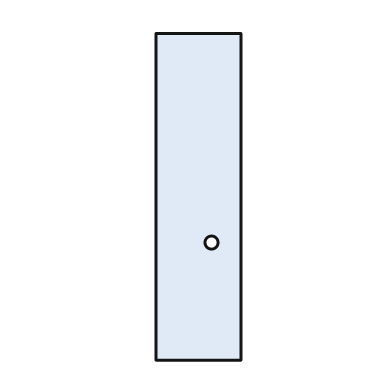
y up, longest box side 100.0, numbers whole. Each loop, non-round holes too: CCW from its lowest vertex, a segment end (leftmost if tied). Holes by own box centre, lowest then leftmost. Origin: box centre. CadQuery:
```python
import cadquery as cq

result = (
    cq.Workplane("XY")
    .moveTo(-13.0, -50.0)
    .lineTo(13.0, -50.0)
    .lineTo(13.0, 50.0)
    .lineTo(-13.0, 50.0)
    .close()
    .moveTo(4.0, -14.0)
    .circle(2.0)
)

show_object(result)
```